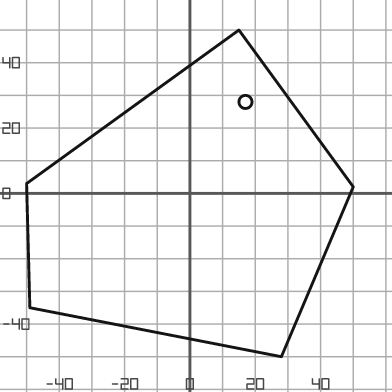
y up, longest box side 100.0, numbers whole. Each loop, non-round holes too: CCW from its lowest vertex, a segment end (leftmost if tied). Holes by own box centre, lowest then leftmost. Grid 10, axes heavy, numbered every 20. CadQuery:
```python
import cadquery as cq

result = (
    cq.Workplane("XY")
    .moveTo(28.0, -50.0)
    .lineTo(50.0, 2.0)
    .lineTo(15.0, 50.0)
    .lineTo(-50.0, 3.0)
    .lineTo(-49.0, -35.0)
    .close()
    .moveTo(17.0, 28.0)
    .circle(2.0)
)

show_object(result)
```